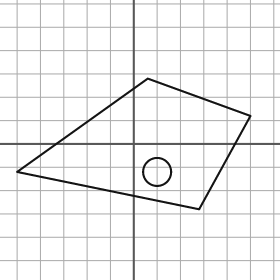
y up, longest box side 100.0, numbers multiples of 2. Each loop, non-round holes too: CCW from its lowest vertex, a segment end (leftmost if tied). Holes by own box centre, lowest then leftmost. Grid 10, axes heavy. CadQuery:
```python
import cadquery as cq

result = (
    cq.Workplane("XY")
    .moveTo(28.0, -28.0)
    .lineTo(50.0, 12.0)
    .lineTo(6.0, 28.0)
    .lineTo(-50.0, -12.0)
    .close()
    .moveTo(10.0, -12.0)
    .circle(6.0)
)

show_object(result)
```